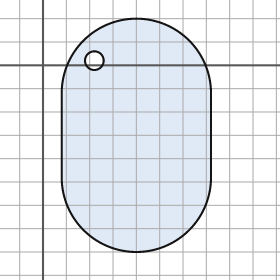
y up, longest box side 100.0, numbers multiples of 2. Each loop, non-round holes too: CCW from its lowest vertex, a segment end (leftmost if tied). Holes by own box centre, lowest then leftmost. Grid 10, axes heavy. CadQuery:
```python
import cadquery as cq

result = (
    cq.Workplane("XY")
    .moveTo(8.0, -48.0)
    .threePointArc((40.0, -80.0), (72.0, -48.0))
    .lineTo(72.0, -12.0)
    .threePointArc((40.0, 20.0), (8.0, -12.0))
    .close()
    .moveTo(22.0, 2.0)
    .circle(4.0)
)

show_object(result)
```